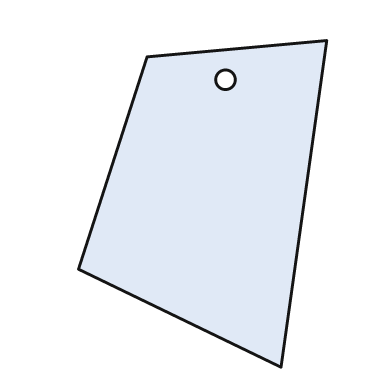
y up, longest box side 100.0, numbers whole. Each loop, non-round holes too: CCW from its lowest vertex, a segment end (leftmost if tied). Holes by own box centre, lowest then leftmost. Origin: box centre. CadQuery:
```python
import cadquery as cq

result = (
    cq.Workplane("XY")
    .moveTo(24.0, -50.0)
    .lineTo(38.0, 50.0)
    .lineTo(-17.0, 45.0)
    .lineTo(-38.0, -20.0)
    .close()
    .moveTo(7.0, 38.0)
    .circle(3.0)
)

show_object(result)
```